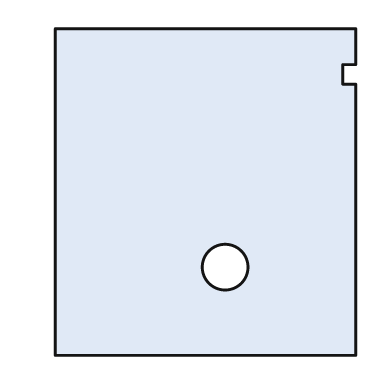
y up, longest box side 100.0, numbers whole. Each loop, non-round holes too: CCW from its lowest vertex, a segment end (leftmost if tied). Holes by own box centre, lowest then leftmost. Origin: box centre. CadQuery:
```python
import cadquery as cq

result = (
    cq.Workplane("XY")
    .moveTo(-46.0, -50.0)
    .lineTo(46.0, -50.0)
    .lineTo(46.0, 33.0)
    .lineTo(42.0, 33.0)
    .lineTo(42.0, 39.0)
    .lineTo(46.0, 39.0)
    .lineTo(46.0, 50.0)
    .lineTo(-46.0, 50.0)
    .close()
    .moveTo(6.0, -23.0)
    .circle(7.0)
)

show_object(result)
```